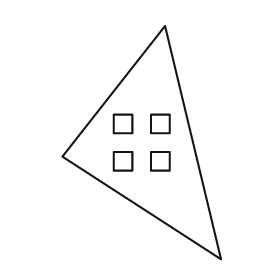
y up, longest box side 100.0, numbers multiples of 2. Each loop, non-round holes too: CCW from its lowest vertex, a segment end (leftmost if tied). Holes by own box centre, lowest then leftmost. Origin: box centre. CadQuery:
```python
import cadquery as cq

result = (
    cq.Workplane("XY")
    .moveTo(34.0, -50.0)
    .lineTo(10.0, 50.0)
    .lineTo(-34.0, -6.0)
    .close()
    .moveTo(-12.0, -12.0)
    .lineTo(-4.0, -12.0)
    .lineTo(-4.0, -4.0)
    .lineTo(-12.0, -4.0)
    .close()
    .moveTo(4.0, -12.0)
    .lineTo(12.0, -12.0)
    .lineTo(12.0, -4.0)
    .lineTo(4.0, -4.0)
    .close()
    .moveTo(-12.0, 4.0)
    .lineTo(-4.0, 4.0)
    .lineTo(-4.0, 12.0)
    .lineTo(-12.0, 12.0)
    .close()
    .moveTo(4.0, 4.0)
    .lineTo(12.0, 4.0)
    .lineTo(12.0, 12.0)
    .lineTo(4.0, 12.0)
    .close()
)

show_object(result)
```